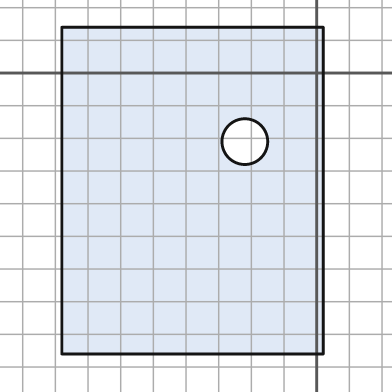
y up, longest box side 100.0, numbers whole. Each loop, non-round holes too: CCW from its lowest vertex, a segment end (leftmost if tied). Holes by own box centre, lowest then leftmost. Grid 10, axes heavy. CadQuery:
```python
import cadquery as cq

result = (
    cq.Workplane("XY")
    .moveTo(-78.0, -86.0)
    .lineTo(2.0, -86.0)
    .lineTo(2.0, 14.0)
    .lineTo(-78.0, 14.0)
    .close()
    .moveTo(-22.0, -21.0)
    .circle(7.0)
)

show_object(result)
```